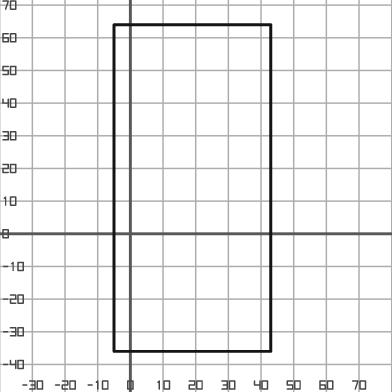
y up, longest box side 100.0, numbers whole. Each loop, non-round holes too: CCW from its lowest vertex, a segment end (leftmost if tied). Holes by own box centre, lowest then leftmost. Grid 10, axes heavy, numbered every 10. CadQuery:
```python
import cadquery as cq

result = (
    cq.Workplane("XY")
    .moveTo(-5.0, -36.0)
    .lineTo(43.0, -36.0)
    .lineTo(43.0, 64.0)
    .lineTo(-5.0, 64.0)
    .close()
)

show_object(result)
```